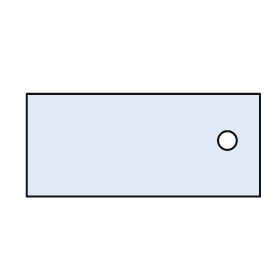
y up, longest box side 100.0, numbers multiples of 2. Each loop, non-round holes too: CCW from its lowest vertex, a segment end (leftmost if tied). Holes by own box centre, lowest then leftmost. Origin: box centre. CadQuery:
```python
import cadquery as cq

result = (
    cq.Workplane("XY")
    .moveTo(-50.0, -22.0)
    .lineTo(50.0, -22.0)
    .lineTo(50.0, 22.0)
    .lineTo(-50.0, 22.0)
    .close()
    .moveTo(36.0, 2.0)
    .circle(4.0)
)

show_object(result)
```